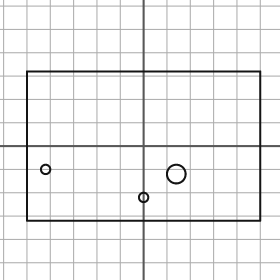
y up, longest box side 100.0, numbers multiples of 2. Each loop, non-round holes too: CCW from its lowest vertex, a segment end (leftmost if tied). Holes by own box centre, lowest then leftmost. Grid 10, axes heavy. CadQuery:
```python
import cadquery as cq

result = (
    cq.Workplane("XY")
    .moveTo(-50.0, -32.0)
    .lineTo(50.0, -32.0)
    .lineTo(50.0, 32.0)
    .lineTo(-50.0, 32.0)
    .close()
    .moveTo(0.0, -22.0)
    .circle(2.0)
    .moveTo(14.0, -12.0)
    .circle(4.0)
    .moveTo(-42.0, -10.0)
    .circle(2.0)
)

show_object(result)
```